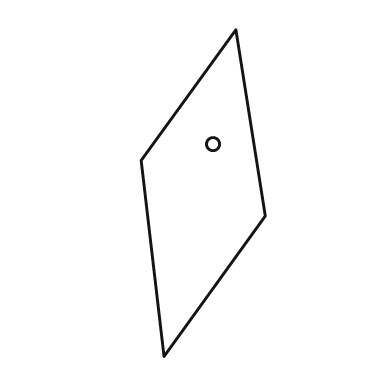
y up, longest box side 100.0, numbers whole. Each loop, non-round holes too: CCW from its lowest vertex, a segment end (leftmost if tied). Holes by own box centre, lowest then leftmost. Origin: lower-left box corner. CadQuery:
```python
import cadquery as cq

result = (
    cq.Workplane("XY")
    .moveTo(7.0, 0.0)
    .lineTo(38.0, 43.0)
    .lineTo(29.0, 100.0)
    .lineTo(0.0, 60.0)
    .close()
    .moveTo(22.0, 65.0)
    .circle(2.0)
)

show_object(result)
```